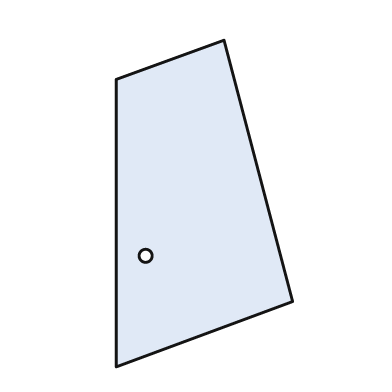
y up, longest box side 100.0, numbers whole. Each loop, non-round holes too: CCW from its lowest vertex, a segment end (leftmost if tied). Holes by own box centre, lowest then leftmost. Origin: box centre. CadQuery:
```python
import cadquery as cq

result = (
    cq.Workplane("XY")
    .moveTo(-27.0, -50.0)
    .lineTo(27.0, -30.0)
    .lineTo(6.0, 50.0)
    .lineTo(-27.0, 38.0)
    .close()
    .moveTo(-18.0, -16.0)
    .circle(2.0)
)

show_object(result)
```